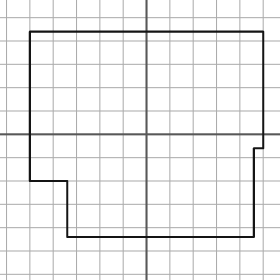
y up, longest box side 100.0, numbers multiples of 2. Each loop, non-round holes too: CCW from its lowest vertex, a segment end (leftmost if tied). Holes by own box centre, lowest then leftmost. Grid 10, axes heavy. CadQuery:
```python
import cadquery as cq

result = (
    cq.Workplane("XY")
    .moveTo(-34.0, -44.0)
    .lineTo(46.0, -44.0)
    .lineTo(46.0, -6.0)
    .lineTo(50.0, -6.0)
    .lineTo(50.0, 44.0)
    .lineTo(-50.0, 44.0)
    .lineTo(-50.0, -20.0)
    .lineTo(-34.0, -20.0)
    .close()
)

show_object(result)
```